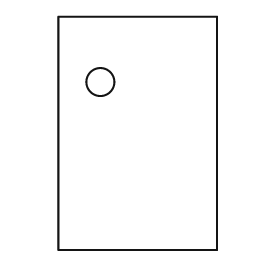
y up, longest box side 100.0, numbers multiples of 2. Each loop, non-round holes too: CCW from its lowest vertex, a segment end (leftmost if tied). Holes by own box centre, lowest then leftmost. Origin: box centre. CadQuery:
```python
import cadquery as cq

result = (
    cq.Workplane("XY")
    .moveTo(-34.0, -50.0)
    .lineTo(34.0, -50.0)
    .lineTo(34.0, 50.0)
    .lineTo(-34.0, 50.0)
    .close()
    .moveTo(-16.0, 22.0)
    .circle(6.0)
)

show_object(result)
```